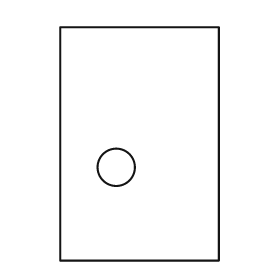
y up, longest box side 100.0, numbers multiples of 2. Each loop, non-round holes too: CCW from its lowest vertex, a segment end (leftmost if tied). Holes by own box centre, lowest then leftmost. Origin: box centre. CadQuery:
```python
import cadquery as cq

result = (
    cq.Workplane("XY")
    .moveTo(-34.0, -50.0)
    .lineTo(34.0, -50.0)
    .lineTo(34.0, 50.0)
    .lineTo(-34.0, 50.0)
    .close()
    .moveTo(-10.0, -10.0)
    .circle(8.0)
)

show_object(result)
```